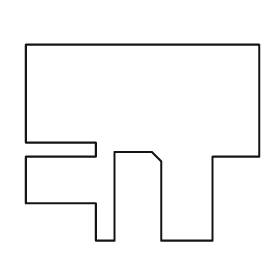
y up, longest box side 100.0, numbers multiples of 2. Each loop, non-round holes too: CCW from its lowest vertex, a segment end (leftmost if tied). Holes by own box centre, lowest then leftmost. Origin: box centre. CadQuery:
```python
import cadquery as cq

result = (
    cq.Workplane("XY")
    .moveTo(-20.0, -42.0)
    .lineTo(-12.0, -42.0)
    .lineTo(-12.0, -4.0)
    .lineTo(4.0, -4.0)
    .lineTo(8.0, -8.0)
    .lineTo(8.0, -42.0)
    .lineTo(30.0, -42.0)
    .lineTo(30.0, -6.0)
    .lineTo(50.0, -6.0)
    .lineTo(50.0, 42.0)
    .lineTo(-50.0, 42.0)
    .lineTo(-50.0, 0.0)
    .lineTo(-20.0, 0.0)
    .lineTo(-20.0, -6.0)
    .lineTo(-50.0, -6.0)
    .lineTo(-50.0, -26.0)
    .lineTo(-20.0, -26.0)
    .close()
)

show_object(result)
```